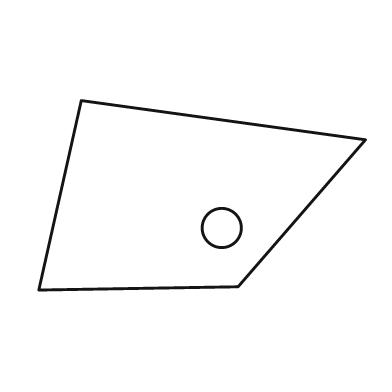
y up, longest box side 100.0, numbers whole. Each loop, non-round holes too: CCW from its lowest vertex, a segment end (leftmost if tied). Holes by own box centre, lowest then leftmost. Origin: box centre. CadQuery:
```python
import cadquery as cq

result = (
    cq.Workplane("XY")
    .moveTo(-50.0, -29.0)
    .lineTo(11.0, -28.0)
    .lineTo(50.0, 17.0)
    .lineTo(-37.0, 29.0)
    .close()
    .moveTo(6.0, -10.0)
    .circle(6.0)
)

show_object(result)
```